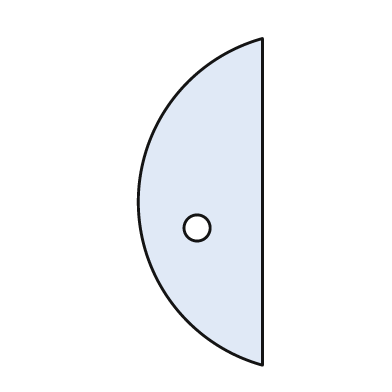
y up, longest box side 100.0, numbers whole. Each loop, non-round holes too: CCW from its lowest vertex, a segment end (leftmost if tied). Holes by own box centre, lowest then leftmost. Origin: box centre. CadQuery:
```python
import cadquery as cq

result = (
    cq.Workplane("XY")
    .moveTo(19.0, -50.0)
    .lineTo(19.0, 50.0)
    .threePointArc((-19.0, 0.0), (19.0, -50.0))
    .close()
    .moveTo(-1.0, -8.0)
    .circle(4.0)
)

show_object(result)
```